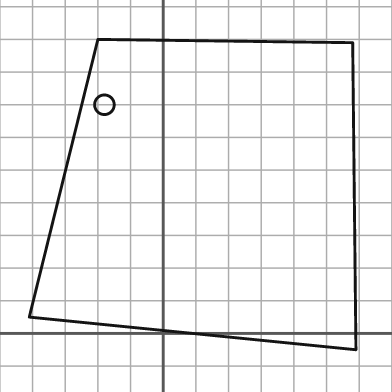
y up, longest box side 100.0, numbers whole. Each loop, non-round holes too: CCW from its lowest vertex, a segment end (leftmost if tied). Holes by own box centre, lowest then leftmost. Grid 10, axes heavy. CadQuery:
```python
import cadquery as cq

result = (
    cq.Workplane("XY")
    .moveTo(59.0, -5.0)
    .lineTo(58.0, 89.0)
    .lineTo(-20.0, 90.0)
    .lineTo(-41.0, 5.0)
    .close()
    .moveTo(-18.0, 70.0)
    .circle(3.0)
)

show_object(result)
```